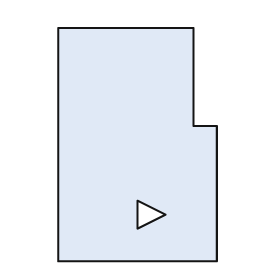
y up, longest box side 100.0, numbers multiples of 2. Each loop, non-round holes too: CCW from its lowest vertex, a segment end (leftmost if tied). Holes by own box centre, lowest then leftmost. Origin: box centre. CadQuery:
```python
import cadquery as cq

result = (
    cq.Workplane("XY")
    .moveTo(-34.0, -50.0)
    .lineTo(34.0, -50.0)
    .lineTo(34.0, 8.0)
    .lineTo(24.0, 8.0)
    .lineTo(24.0, 50.0)
    .lineTo(-34.0, 50.0)
    .close()
    .moveTo(0.0, -36.0)
    .lineTo(12.0, -30.0)
    .lineTo(0.0, -24.0)
    .close()
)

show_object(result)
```